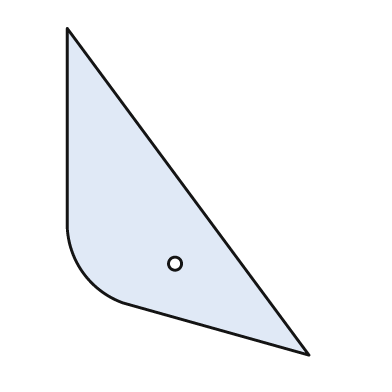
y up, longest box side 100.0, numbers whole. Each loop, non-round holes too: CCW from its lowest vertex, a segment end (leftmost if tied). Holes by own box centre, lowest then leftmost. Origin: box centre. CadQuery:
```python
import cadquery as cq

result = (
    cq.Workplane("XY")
    .moveTo(37.0, -50.0)
    .lineTo(-37.0, 50.0)
    .lineTo(-37.0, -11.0)
    .threePointArc((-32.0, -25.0), (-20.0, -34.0))
    .close()
    .moveTo(-4.0, -22.0)
    .circle(2.0)
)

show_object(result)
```